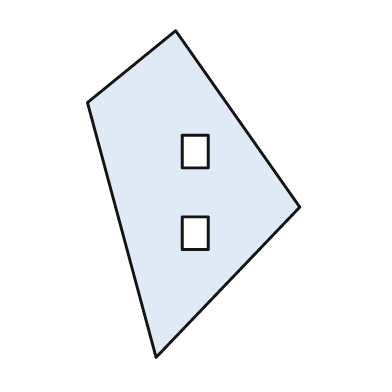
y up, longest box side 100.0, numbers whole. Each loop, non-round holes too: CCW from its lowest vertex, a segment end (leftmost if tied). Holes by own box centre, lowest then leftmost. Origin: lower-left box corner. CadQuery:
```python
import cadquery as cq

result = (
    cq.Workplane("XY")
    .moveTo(21.0, 0.0)
    .lineTo(65.0, 46.0)
    .lineTo(27.0, 100.0)
    .lineTo(0.0, 78.0)
    .close()
    .moveTo(29.0, 33.0)
    .lineTo(37.0, 33.0)
    .lineTo(37.0, 43.0)
    .lineTo(29.0, 43.0)
    .close()
    .moveTo(29.0, 58.0)
    .lineTo(37.0, 58.0)
    .lineTo(37.0, 68.0)
    .lineTo(29.0, 68.0)
    .close()
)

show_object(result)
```